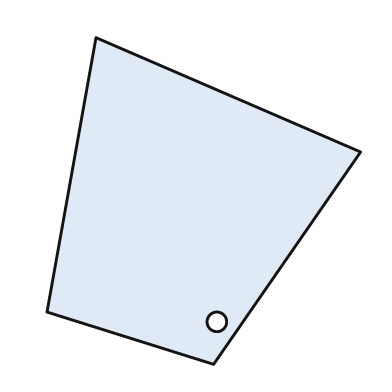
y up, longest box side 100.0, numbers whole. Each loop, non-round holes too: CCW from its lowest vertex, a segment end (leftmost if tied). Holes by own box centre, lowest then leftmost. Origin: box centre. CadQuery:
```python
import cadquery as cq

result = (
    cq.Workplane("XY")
    .moveTo(3.0, -50.0)
    .lineTo(48.0, 15.0)
    .lineTo(-33.0, 50.0)
    .lineTo(-48.0, -34.0)
    .close()
    .moveTo(4.0, -37.0)
    .circle(3.0)
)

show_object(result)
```